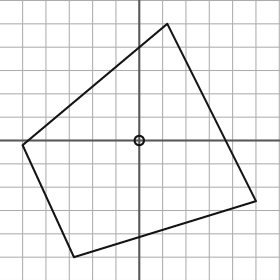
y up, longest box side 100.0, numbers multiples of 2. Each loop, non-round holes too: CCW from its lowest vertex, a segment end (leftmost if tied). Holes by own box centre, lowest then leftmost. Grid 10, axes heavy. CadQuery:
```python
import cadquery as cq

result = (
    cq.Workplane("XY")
    .moveTo(-28.0, -50.0)
    .lineTo(50.0, -26.0)
    .lineTo(12.0, 50.0)
    .lineTo(-50.0, -2.0)
    .close()
    .moveTo(0.0, 0.0)
    .circle(2.0)
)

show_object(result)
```